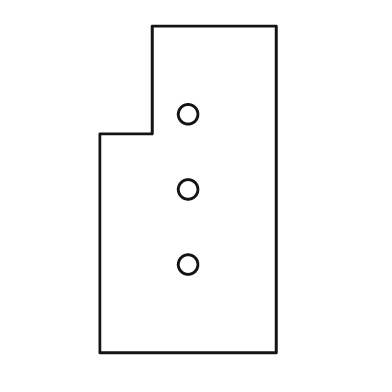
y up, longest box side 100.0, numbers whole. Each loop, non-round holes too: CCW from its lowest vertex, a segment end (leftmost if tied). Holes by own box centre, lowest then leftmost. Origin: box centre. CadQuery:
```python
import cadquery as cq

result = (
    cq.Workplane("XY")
    .moveTo(-27.0, -50.0)
    .lineTo(27.0, -50.0)
    .lineTo(27.0, 50.0)
    .lineTo(-11.0, 50.0)
    .lineTo(-11.0, 17.0)
    .lineTo(-27.0, 17.0)
    .close()
    .moveTo(0.0, -23.0)
    .circle(3.0)
    .moveTo(0.0, 0.0)
    .circle(3.0)
    .moveTo(0.0, 23.0)
    .circle(3.0)
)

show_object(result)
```